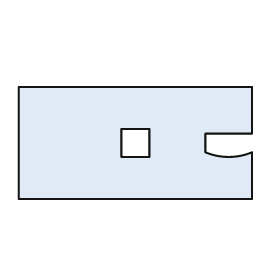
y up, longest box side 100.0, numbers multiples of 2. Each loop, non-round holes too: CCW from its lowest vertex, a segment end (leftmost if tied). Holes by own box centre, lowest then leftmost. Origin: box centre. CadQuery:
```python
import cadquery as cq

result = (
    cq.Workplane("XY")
    .moveTo(-50.0, -24.0)
    .lineTo(50.0, -24.0)
    .lineTo(50.0, -4.0)
    .threePointArc((40.0, -6.0), (30.0, -4.0))
    .lineTo(30.0, 4.0)
    .lineTo(50.0, 4.0)
    .lineTo(50.0, 24.0)
    .lineTo(-50.0, 24.0)
    .close()
    .moveTo(-6.0, -6.0)
    .lineTo(6.0, -6.0)
    .lineTo(6.0, 6.0)
    .lineTo(-6.0, 6.0)
    .close()
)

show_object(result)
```